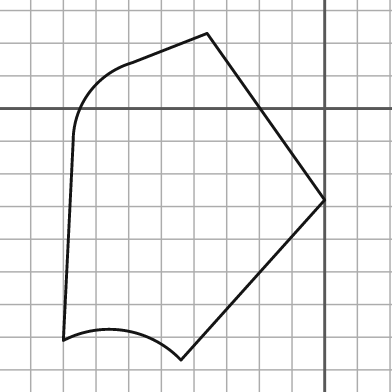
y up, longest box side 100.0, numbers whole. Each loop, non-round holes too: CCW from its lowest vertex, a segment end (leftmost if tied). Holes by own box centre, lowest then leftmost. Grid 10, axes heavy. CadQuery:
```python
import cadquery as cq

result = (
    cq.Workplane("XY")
    .moveTo(-44.0, -77.0)
    .lineTo(0.0, -28.0)
    .lineTo(-36.0, 23.0)
    .lineTo(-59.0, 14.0)
    .threePointArc((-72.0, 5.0), (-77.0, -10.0))
    .lineTo(-80.0, -71.0)
    .threePointArc((-61.0, -68.0), (-44.0, -77.0))
    .close()
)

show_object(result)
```